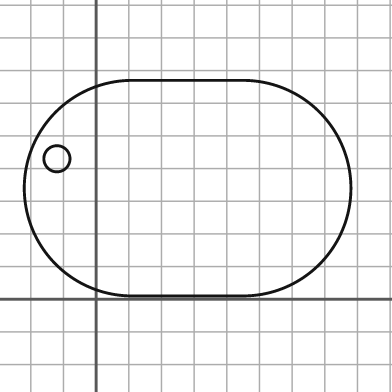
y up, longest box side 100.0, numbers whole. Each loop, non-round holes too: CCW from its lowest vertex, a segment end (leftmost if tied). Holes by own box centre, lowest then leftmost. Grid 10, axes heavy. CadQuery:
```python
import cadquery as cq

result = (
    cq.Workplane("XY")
    .moveTo(11.0, 1.0)
    .lineTo(45.0, 1.0)
    .threePointArc((78.0, 34.0), (45.0, 67.0))
    .lineTo(11.0, 67.0)
    .threePointArc((-22.0, 34.0), (11.0, 1.0))
    .close()
    .moveTo(-12.0, 43.0)
    .circle(4.0)
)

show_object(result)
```